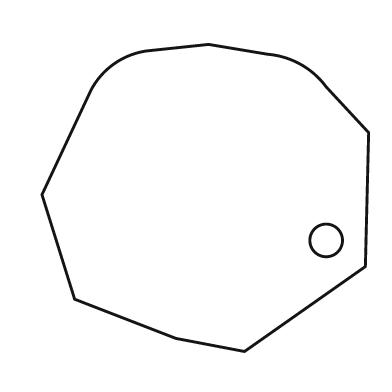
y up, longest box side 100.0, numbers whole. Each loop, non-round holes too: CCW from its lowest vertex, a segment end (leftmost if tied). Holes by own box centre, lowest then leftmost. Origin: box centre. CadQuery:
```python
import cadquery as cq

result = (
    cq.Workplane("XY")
    .moveTo(12.0, -47.0)
    .lineTo(49.0, -21.0)
    .lineTo(50.0, 20.0)
    .lineTo(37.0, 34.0)
    .threePointArc((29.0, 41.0), (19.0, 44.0))
    .lineTo(1.0, 47.0)
    .lineTo(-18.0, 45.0)
    .threePointArc((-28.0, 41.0), (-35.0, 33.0))
    .lineTo(-50.0, 1.0)
    .lineTo(-40.0, -31.0)
    .lineTo(-9.0, -43.0)
    .close()
    .moveTo(37.0, -13.0)
    .circle(5.0)
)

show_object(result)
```